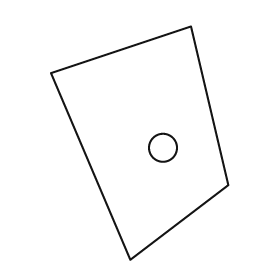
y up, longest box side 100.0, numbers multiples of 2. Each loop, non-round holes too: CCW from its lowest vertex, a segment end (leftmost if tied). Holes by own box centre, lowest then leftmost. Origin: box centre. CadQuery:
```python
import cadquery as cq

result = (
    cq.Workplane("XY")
    .moveTo(-4.0, -50.0)
    .lineTo(38.0, -18.0)
    .lineTo(22.0, 50.0)
    .lineTo(-38.0, 30.0)
    .close()
    .moveTo(10.0, -2.0)
    .circle(6.0)
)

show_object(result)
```